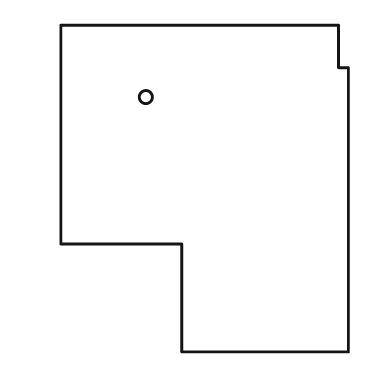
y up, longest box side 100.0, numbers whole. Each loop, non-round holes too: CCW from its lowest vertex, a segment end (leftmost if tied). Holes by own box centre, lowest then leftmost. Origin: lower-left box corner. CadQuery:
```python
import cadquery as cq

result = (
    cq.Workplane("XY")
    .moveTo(37.0, 0.0)
    .lineTo(88.0, 0.0)
    .lineTo(88.0, 87.0)
    .lineTo(85.0, 87.0)
    .lineTo(85.0, 100.0)
    .lineTo(0.0, 100.0)
    .lineTo(0.0, 33.0)
    .lineTo(37.0, 33.0)
    .close()
    .moveTo(26.0, 78.0)
    .circle(2.0)
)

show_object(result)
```